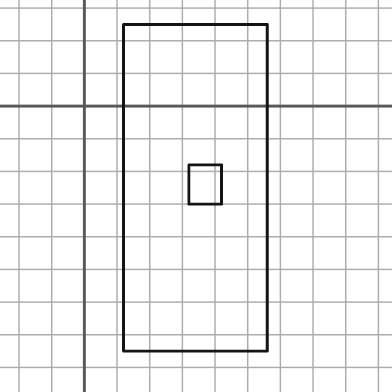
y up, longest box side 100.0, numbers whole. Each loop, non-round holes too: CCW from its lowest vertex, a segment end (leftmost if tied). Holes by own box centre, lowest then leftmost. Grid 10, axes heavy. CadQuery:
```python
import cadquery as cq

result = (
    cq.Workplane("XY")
    .moveTo(12.0, -75.0)
    .lineTo(56.0, -75.0)
    .lineTo(56.0, 25.0)
    .lineTo(12.0, 25.0)
    .close()
    .moveTo(32.0, -30.0)
    .lineTo(42.0, -30.0)
    .lineTo(42.0, -18.0)
    .lineTo(32.0, -18.0)
    .close()
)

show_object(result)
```